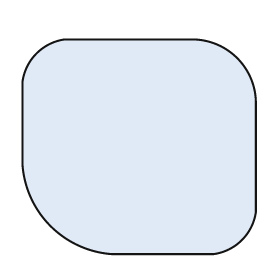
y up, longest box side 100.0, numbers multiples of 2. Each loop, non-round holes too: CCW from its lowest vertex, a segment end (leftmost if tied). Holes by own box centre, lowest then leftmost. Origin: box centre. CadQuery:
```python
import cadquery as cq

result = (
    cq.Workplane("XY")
    .moveTo(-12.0, -46.0)
    .lineTo(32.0, -46.0)
    .threePointArc((44.0, -40.0), (50.0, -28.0))
    .lineTo(50.0, 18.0)
    .threePointArc((42.0, 38.0), (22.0, 46.0))
    .lineTo(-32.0, 46.0)
    .threePointArc((-44.0, 40.0), (-50.0, 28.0))
    .lineTo(-50.0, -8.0)
    .threePointArc((-38.0, -34.0), (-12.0, -46.0))
    .close()
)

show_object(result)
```